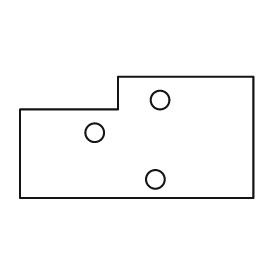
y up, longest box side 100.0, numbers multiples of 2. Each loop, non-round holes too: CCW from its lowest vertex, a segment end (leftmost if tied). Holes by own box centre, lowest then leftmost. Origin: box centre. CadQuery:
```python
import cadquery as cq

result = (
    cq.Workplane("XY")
    .moveTo(-50.0, -26.0)
    .lineTo(50.0, -26.0)
    .lineTo(50.0, 26.0)
    .lineTo(-8.0, 26.0)
    .lineTo(-8.0, 12.0)
    .lineTo(-50.0, 12.0)
    .close()
    .moveTo(8.0, -18.0)
    .circle(4.0)
    .moveTo(-18.0, 2.0)
    .circle(4.0)
    .moveTo(10.0, 16.0)
    .circle(4.0)
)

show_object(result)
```